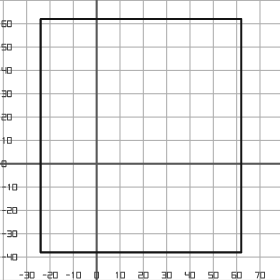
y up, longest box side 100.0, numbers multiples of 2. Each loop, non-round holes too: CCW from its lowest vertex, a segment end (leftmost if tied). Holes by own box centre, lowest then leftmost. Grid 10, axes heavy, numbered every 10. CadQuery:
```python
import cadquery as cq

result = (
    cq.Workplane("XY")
    .moveTo(-24.0, -38.0)
    .lineTo(62.0, -38.0)
    .lineTo(62.0, 62.0)
    .lineTo(-24.0, 62.0)
    .close()
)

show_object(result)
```